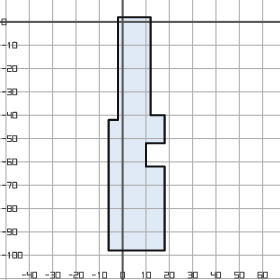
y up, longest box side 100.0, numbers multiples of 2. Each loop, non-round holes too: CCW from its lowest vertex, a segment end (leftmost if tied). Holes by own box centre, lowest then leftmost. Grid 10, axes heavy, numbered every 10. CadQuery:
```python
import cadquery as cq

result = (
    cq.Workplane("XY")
    .moveTo(-6.0, -98.0)
    .lineTo(18.0, -98.0)
    .lineTo(18.0, -62.0)
    .lineTo(10.0, -62.0)
    .lineTo(10.0, -52.0)
    .lineTo(18.0, -52.0)
    .lineTo(18.0, -40.0)
    .lineTo(12.0, -40.0)
    .lineTo(12.0, 2.0)
    .lineTo(-2.0, 2.0)
    .lineTo(-2.0, -42.0)
    .lineTo(-6.0, -42.0)
    .close()
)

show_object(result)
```